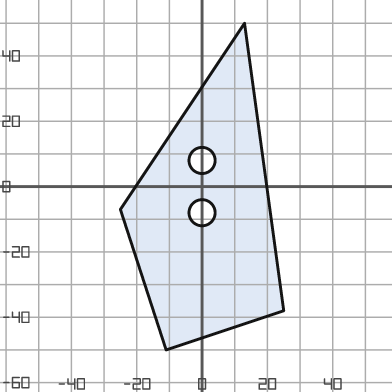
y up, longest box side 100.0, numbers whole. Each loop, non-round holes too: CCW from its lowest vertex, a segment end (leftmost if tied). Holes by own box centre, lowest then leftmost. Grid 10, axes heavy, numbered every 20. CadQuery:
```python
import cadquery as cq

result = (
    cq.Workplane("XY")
    .moveTo(-11.0, -50.0)
    .lineTo(25.0, -38.0)
    .lineTo(13.0, 50.0)
    .lineTo(-25.0, -7.0)
    .close()
    .moveTo(0.0, -8.0)
    .circle(4.0)
    .moveTo(0.0, 8.0)
    .circle(4.0)
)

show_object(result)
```